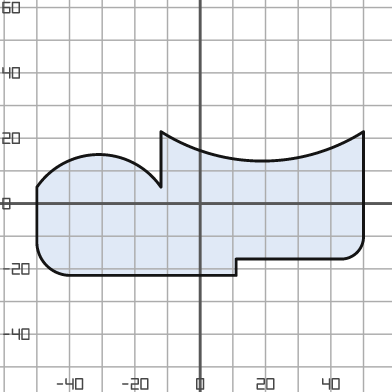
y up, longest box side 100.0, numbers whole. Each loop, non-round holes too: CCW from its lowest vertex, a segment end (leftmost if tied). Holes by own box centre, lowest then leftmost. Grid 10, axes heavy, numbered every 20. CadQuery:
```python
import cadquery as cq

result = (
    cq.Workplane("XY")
    .moveTo(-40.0, -22.0)
    .lineTo(11.0, -22.0)
    .lineTo(11.0, -17.0)
    .lineTo(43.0, -17.0)
    .threePointArc((48.0, -15.0), (50.0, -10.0))
    .lineTo(50.0, 22.0)
    .threePointArc((19.0, 13.0), (-12.0, 22.0))
    .lineTo(-12.0, 5.0)
    .threePointArc((-31.0, 15.0), (-50.0, 5.0))
    .lineTo(-50.0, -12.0)
    .threePointArc((-47.0, -19.0), (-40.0, -22.0))
    .close()
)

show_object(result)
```